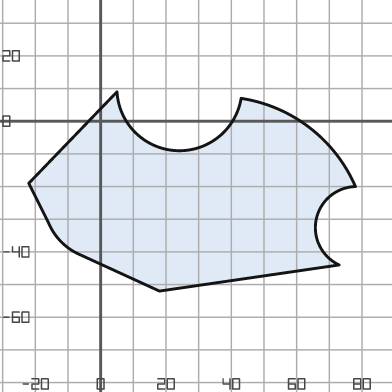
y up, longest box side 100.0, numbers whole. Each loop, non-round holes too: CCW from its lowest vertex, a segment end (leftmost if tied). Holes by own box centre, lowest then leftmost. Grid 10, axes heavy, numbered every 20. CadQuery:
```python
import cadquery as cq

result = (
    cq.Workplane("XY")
    .moveTo(18.0, -52.0)
    .lineTo(73.0, -44.0)
    .threePointArc((66.0, -30.0), (78.0, -20.0))
    .threePointArc((64.0, -2.0), (43.0, 7.0))
    .threePointArc((23.0, -9.0), (5.0, 9.0))
    .lineTo(-22.0, -19.0)
    .lineTo(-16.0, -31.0)
    .threePointArc((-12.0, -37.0), (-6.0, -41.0))
    .close()
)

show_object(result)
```